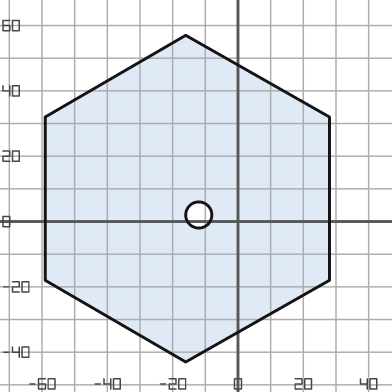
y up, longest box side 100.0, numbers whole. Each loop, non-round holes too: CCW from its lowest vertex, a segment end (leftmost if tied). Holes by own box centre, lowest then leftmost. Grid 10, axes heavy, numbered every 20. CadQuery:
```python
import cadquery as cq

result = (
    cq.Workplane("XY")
    .moveTo(-16.0, -43.0)
    .lineTo(28.0, -18.0)
    .lineTo(28.0, 32.0)
    .lineTo(-16.0, 57.0)
    .lineTo(-59.0, 32.0)
    .lineTo(-59.0, -18.0)
    .close()
    .moveTo(-12.0, 2.0)
    .circle(4.0)
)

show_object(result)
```